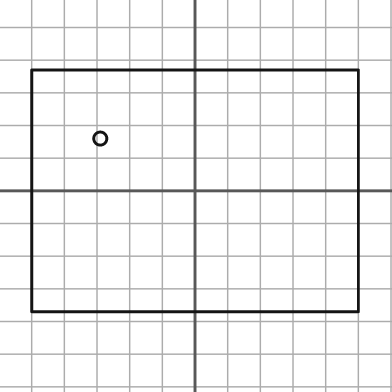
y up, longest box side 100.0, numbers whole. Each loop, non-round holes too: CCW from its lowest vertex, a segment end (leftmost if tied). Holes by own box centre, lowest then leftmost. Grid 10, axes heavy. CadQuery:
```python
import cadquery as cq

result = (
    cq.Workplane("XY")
    .moveTo(-50.0, -37.0)
    .lineTo(50.0, -37.0)
    .lineTo(50.0, 37.0)
    .lineTo(-50.0, 37.0)
    .close()
    .moveTo(-29.0, 16.0)
    .circle(2.0)
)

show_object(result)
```